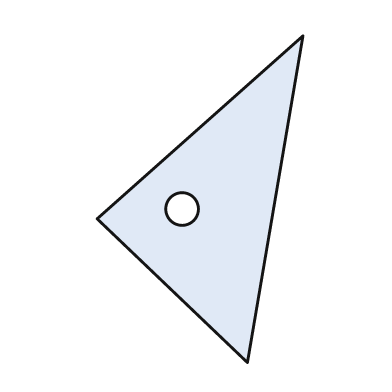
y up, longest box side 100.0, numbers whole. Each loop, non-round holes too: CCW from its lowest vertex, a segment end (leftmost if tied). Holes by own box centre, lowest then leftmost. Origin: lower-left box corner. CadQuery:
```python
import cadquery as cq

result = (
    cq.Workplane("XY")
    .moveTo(46.0, 0.0)
    .lineTo(63.0, 100.0)
    .lineTo(0.0, 44.0)
    .close()
    .moveTo(26.0, 47.0)
    .circle(5.0)
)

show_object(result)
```